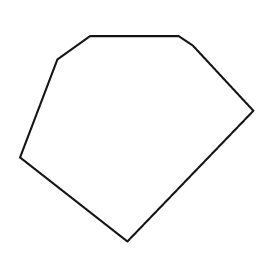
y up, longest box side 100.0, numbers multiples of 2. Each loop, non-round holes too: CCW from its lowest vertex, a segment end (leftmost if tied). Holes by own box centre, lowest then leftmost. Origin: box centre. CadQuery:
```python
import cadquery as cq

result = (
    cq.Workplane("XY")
    .moveTo(-4.0, -44.0)
    .lineTo(50.0, 12.0)
    .lineTo(24.0, 40.0)
    .lineTo(18.0, 44.0)
    .lineTo(-20.0, 44.0)
    .lineTo(-34.0, 34.0)
    .lineTo(-50.0, -8.0)
    .close()
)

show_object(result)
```